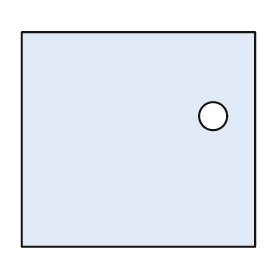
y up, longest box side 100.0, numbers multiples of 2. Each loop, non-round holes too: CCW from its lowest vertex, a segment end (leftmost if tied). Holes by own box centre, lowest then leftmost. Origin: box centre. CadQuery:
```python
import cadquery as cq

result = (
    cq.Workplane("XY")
    .moveTo(-50.0, -46.0)
    .lineTo(50.0, -46.0)
    .lineTo(50.0, 46.0)
    .lineTo(-50.0, 46.0)
    .close()
    .moveTo(32.0, 10.0)
    .circle(6.0)
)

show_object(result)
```